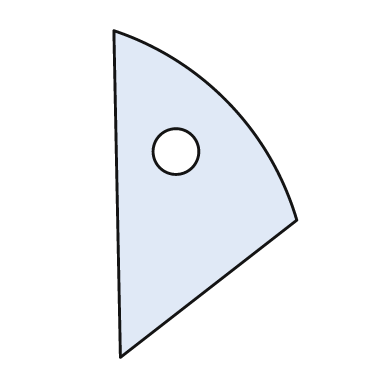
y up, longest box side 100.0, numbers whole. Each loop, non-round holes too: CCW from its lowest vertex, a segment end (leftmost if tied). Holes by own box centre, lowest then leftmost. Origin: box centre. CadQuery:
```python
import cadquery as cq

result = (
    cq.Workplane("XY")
    .moveTo(-26.0, -50.0)
    .lineTo(28.0, -8.0)
    .threePointArc((7.0, 28.0), (-28.0, 50.0))
    .close()
    .moveTo(-9.0, 13.0)
    .circle(7.0)
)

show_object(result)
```